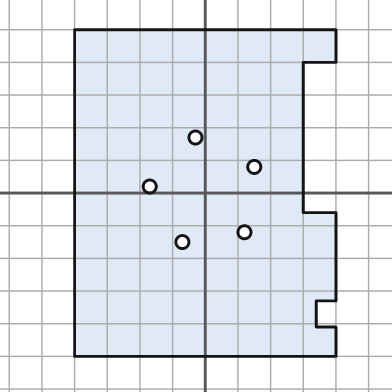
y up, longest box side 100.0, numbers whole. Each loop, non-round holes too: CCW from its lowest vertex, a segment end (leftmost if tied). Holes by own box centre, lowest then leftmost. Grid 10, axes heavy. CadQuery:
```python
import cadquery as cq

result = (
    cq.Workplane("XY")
    .moveTo(-40.0, -50.0)
    .lineTo(40.0, -50.0)
    .lineTo(40.0, -41.0)
    .lineTo(34.0, -41.0)
    .lineTo(34.0, -33.0)
    .lineTo(40.0, -33.0)
    .lineTo(40.0, -6.0)
    .lineTo(30.0, -6.0)
    .lineTo(30.0, 40.0)
    .lineTo(40.0, 40.0)
    .lineTo(40.0, 50.0)
    .lineTo(-40.0, 50.0)
    .close()
    .moveTo(-7.0, -15.0)
    .circle(2.0)
    .moveTo(12.0, -12.0)
    .circle(2.0)
    .moveTo(-17.0, 2.0)
    .circle(2.0)
    .moveTo(15.0, 8.0)
    .circle(2.0)
    .moveTo(-3.0, 17.0)
    .circle(2.0)
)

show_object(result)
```